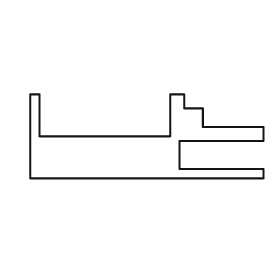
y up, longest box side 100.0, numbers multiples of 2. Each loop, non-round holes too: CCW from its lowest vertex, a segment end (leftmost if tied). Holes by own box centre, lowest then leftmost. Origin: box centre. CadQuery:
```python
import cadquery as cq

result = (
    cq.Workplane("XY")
    .moveTo(-50.0, -18.0)
    .lineTo(50.0, -18.0)
    .lineTo(50.0, -14.0)
    .lineTo(14.0, -14.0)
    .lineTo(14.0, -2.0)
    .lineTo(50.0, -2.0)
    .lineTo(50.0, 4.0)
    .lineTo(24.0, 4.0)
    .lineTo(24.0, 12.0)
    .lineTo(16.0, 12.0)
    .lineTo(16.0, 18.0)
    .lineTo(10.0, 18.0)
    .lineTo(10.0, 0.0)
    .lineTo(-46.0, 0.0)
    .lineTo(-46.0, 18.0)
    .lineTo(-50.0, 18.0)
    .close()
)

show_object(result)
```